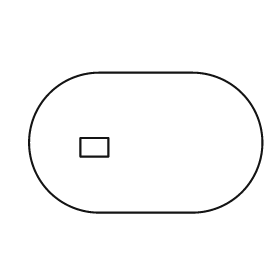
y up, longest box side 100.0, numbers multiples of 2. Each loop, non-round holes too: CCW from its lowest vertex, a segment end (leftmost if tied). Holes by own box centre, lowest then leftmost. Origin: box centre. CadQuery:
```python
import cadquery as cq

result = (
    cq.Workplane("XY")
    .moveTo(-20.0, -30.0)
    .lineTo(20.0, -30.0)
    .threePointArc((50.0, 0.0), (20.0, 30.0))
    .lineTo(-20.0, 30.0)
    .threePointArc((-50.0, 0.0), (-20.0, -30.0))
    .close()
    .moveTo(-28.0, -6.0)
    .lineTo(-16.0, -6.0)
    .lineTo(-16.0, 2.0)
    .lineTo(-28.0, 2.0)
    .close()
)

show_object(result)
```